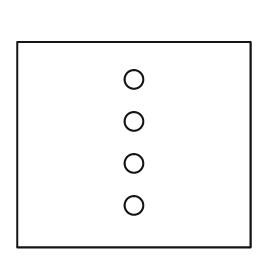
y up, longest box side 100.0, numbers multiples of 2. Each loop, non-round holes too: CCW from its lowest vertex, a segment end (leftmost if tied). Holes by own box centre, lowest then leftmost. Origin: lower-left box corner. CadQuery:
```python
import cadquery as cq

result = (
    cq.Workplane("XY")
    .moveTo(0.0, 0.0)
    .lineTo(100.0, 0.0)
    .lineTo(100.0, 88.0)
    .lineTo(0.0, 88.0)
    .close()
    .moveTo(50.0, 18.0)
    .circle(4.0)
    .moveTo(50.0, 36.0)
    .circle(4.0)
    .moveTo(50.0, 54.0)
    .circle(4.0)
    .moveTo(50.0, 72.0)
    .circle(4.0)
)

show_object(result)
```